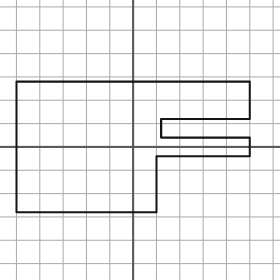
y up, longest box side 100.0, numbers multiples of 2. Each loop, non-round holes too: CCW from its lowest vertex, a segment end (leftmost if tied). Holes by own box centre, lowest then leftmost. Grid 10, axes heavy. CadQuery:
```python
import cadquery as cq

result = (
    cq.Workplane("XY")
    .moveTo(-50.0, -28.0)
    .lineTo(10.0, -28.0)
    .lineTo(10.0, -4.0)
    .lineTo(50.0, -4.0)
    .lineTo(50.0, 4.0)
    .lineTo(12.0, 4.0)
    .lineTo(12.0, 12.0)
    .lineTo(50.0, 12.0)
    .lineTo(50.0, 28.0)
    .lineTo(-50.0, 28.0)
    .close()
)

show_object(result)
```